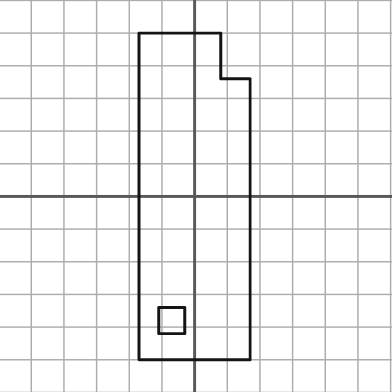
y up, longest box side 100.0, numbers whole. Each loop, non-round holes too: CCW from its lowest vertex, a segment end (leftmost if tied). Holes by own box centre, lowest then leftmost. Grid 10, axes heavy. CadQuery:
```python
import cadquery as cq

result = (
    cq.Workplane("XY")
    .moveTo(-17.0, -50.0)
    .lineTo(17.0, -50.0)
    .lineTo(17.0, 36.0)
    .lineTo(8.0, 36.0)
    .lineTo(8.0, 50.0)
    .lineTo(-17.0, 50.0)
    .close()
    .moveTo(-11.0, -42.0)
    .lineTo(-3.0, -42.0)
    .lineTo(-3.0, -34.0)
    .lineTo(-11.0, -34.0)
    .close()
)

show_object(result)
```